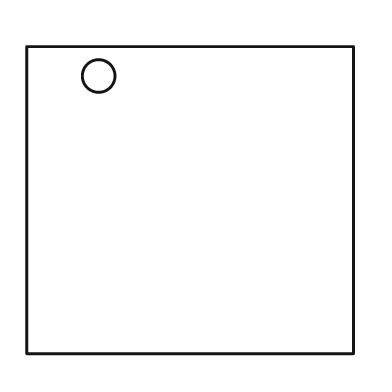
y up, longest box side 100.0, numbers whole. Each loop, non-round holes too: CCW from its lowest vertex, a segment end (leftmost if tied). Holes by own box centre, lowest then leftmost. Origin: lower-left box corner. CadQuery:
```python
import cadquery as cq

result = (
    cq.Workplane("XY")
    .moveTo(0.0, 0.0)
    .lineTo(100.0, 0.0)
    .lineTo(100.0, 94.0)
    .lineTo(0.0, 94.0)
    .close()
    .moveTo(22.0, 85.0)
    .circle(5.0)
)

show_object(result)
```